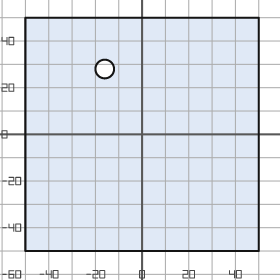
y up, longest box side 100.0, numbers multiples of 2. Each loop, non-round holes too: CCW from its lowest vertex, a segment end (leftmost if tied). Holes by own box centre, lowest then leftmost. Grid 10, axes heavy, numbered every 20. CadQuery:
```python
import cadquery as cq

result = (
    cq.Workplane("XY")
    .moveTo(-50.0, -50.0)
    .lineTo(50.0, -50.0)
    .lineTo(50.0, 50.0)
    .lineTo(-50.0, 50.0)
    .close()
    .moveTo(-16.0, 28.0)
    .circle(4.0)
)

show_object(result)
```